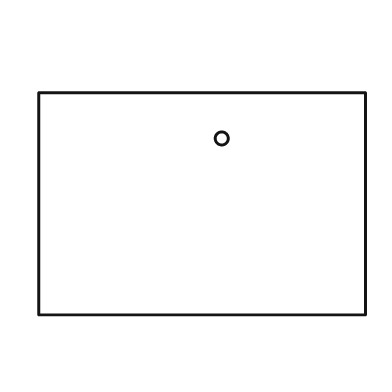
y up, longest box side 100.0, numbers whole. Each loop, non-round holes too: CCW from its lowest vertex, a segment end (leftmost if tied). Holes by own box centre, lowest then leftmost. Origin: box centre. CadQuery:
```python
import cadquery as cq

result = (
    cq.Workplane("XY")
    .moveTo(-50.0, -34.0)
    .lineTo(50.0, -34.0)
    .lineTo(50.0, 34.0)
    .lineTo(-50.0, 34.0)
    .close()
    .moveTo(6.0, 20.0)
    .circle(2.0)
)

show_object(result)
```